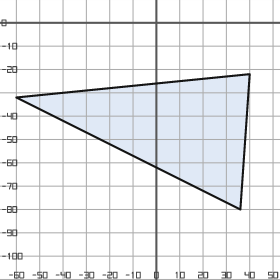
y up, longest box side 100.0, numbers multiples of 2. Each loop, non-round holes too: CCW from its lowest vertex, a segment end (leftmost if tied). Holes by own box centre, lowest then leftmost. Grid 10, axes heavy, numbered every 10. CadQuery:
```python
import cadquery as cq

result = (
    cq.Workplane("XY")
    .moveTo(36.0, -80.0)
    .lineTo(40.0, -22.0)
    .lineTo(-60.0, -32.0)
    .close()
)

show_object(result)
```